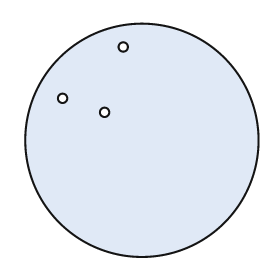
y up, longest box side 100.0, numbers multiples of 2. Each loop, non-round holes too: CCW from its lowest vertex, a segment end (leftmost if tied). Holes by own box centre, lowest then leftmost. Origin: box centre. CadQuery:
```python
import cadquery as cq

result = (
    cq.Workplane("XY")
    .moveTo(0.0, 0.0)
    .circle(50.0)
    .moveTo(-16.0, 12.0)
    .circle(2.0)
    .moveTo(-34.0, 18.0)
    .circle(2.0)
    .moveTo(-8.0, 40.0)
    .circle(2.0)
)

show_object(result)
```